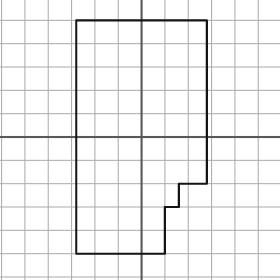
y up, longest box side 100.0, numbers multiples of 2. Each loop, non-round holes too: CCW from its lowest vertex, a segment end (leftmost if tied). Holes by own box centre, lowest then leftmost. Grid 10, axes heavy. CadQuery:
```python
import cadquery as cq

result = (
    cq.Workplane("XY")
    .moveTo(-28.0, -50.0)
    .lineTo(10.0, -50.0)
    .lineTo(10.0, -30.0)
    .lineTo(16.0, -30.0)
    .lineTo(16.0, -20.0)
    .lineTo(28.0, -20.0)
    .lineTo(28.0, 50.0)
    .lineTo(-28.0, 50.0)
    .close()
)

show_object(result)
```